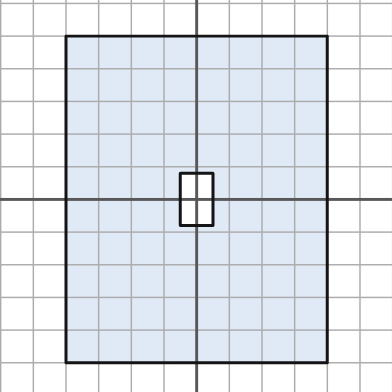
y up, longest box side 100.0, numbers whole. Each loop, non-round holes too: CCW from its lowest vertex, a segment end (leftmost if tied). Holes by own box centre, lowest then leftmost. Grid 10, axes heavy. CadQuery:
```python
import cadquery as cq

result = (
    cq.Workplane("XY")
    .moveTo(-40.0, -50.0)
    .lineTo(40.0, -50.0)
    .lineTo(40.0, 50.0)
    .lineTo(-40.0, 50.0)
    .close()
    .moveTo(-5.0, -8.0)
    .lineTo(5.0, -8.0)
    .lineTo(5.0, 8.0)
    .lineTo(-5.0, 8.0)
    .close()
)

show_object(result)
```